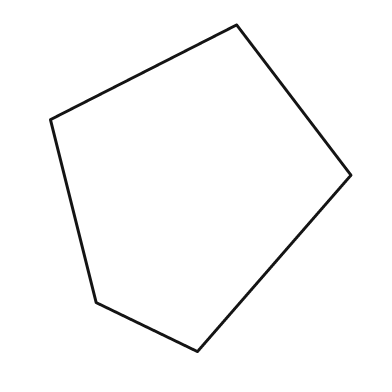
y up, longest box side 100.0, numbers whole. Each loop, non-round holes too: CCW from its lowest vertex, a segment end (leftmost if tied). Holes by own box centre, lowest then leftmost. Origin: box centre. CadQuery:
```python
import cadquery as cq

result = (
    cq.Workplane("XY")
    .moveTo(-1.0, -50.0)
    .lineTo(46.0, 4.0)
    .lineTo(11.0, 50.0)
    .lineTo(-46.0, 21.0)
    .lineTo(-32.0, -35.0)
    .close()
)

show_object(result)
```